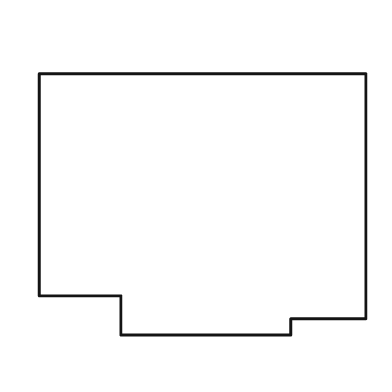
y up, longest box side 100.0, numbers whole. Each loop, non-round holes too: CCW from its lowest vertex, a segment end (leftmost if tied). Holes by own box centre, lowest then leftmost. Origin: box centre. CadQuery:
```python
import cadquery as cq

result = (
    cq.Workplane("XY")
    .moveTo(-25.0, -40.0)
    .lineTo(27.0, -40.0)
    .lineTo(27.0, -35.0)
    .lineTo(50.0, -35.0)
    .lineTo(50.0, 40.0)
    .lineTo(-50.0, 40.0)
    .lineTo(-50.0, -28.0)
    .lineTo(-25.0, -28.0)
    .close()
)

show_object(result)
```